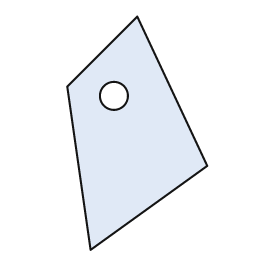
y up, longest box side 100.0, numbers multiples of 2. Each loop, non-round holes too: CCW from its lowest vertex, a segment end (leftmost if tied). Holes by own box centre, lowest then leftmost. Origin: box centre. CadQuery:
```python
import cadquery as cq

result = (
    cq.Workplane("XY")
    .moveTo(-20.0, -50.0)
    .lineTo(30.0, -14.0)
    .lineTo(0.0, 50.0)
    .lineTo(-30.0, 20.0)
    .close()
    .moveTo(-10.0, 16.0)
    .circle(6.0)
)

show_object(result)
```